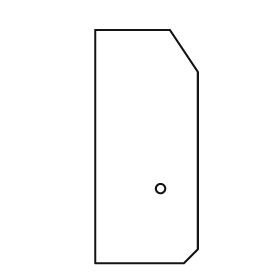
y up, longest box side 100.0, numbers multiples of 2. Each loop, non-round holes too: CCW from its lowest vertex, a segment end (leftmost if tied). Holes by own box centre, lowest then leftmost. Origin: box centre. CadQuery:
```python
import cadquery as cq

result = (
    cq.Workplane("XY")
    .moveTo(-22.0, -50.0)
    .lineTo(16.0, -50.0)
    .lineTo(22.0, -44.0)
    .lineTo(22.0, 32.0)
    .lineTo(10.0, 50.0)
    .lineTo(-22.0, 50.0)
    .close()
    .moveTo(6.0, -18.0)
    .circle(2.0)
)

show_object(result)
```